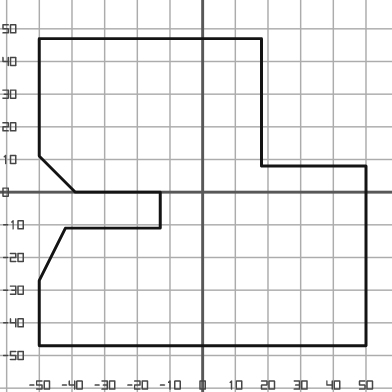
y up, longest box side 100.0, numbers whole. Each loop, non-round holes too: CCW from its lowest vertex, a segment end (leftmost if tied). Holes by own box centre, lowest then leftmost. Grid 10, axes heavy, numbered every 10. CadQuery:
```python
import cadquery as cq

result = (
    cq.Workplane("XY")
    .moveTo(-50.0, -47.0)
    .lineTo(50.0, -47.0)
    .lineTo(50.0, 8.0)
    .lineTo(18.0, 8.0)
    .lineTo(18.0, 47.0)
    .lineTo(-50.0, 47.0)
    .lineTo(-50.0, 11.0)
    .lineTo(-39.0, 0.0)
    .lineTo(-13.0, 0.0)
    .lineTo(-13.0, -11.0)
    .lineTo(-42.0, -11.0)
    .lineTo(-50.0, -27.0)
    .close()
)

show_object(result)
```